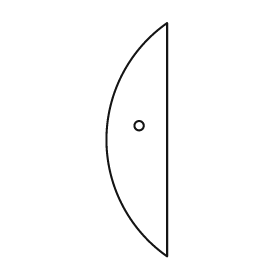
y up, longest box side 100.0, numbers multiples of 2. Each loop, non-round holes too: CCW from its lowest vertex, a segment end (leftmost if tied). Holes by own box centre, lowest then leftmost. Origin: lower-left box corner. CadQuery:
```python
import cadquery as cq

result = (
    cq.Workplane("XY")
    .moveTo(26.0, 0.0)
    .lineTo(26.0, 100.0)
    .threePointArc((0.0, 50.0), (26.0, 0.0))
    .close()
    .moveTo(14.0, 56.0)
    .circle(2.0)
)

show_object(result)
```